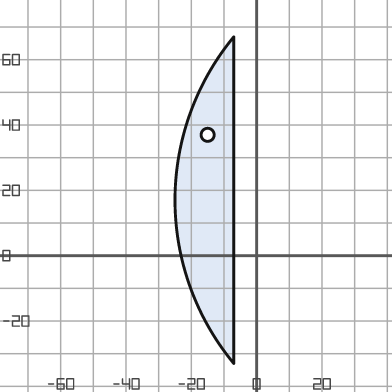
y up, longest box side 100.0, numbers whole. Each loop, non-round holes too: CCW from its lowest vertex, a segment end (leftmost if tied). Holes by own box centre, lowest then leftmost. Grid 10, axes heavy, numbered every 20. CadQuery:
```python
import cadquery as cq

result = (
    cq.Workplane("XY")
    .moveTo(-7.0, -33.0)
    .lineTo(-7.0, 67.0)
    .threePointArc((-25.0, 17.0), (-7.0, -33.0))
    .close()
    .moveTo(-15.0, 37.0)
    .circle(2.0)
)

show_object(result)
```